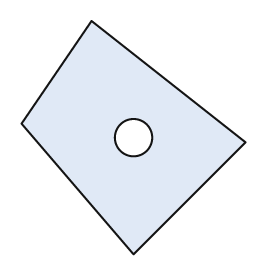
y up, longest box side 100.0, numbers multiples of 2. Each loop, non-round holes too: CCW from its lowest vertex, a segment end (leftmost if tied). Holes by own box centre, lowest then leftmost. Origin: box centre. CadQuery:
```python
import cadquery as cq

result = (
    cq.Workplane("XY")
    .moveTo(0.0, -50.0)
    .lineTo(48.0, -2.0)
    .lineTo(-18.0, 50.0)
    .lineTo(-48.0, 6.0)
    .close()
    .moveTo(0.0, 0.0)
    .circle(8.0)
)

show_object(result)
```